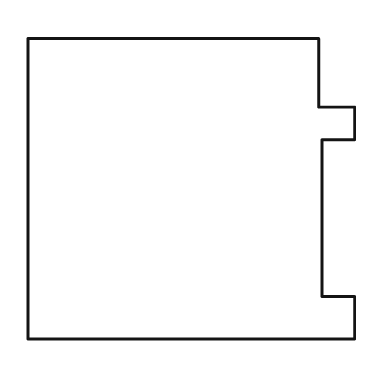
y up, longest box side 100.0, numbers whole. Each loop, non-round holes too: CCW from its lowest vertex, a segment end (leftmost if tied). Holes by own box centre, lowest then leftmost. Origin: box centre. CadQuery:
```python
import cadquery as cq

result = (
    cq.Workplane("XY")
    .moveTo(-50.0, -46.0)
    .lineTo(50.0, -46.0)
    .lineTo(50.0, -33.0)
    .lineTo(40.0, -33.0)
    .lineTo(40.0, 15.0)
    .lineTo(50.0, 15.0)
    .lineTo(50.0, 25.0)
    .lineTo(39.0, 25.0)
    .lineTo(39.0, 46.0)
    .lineTo(-50.0, 46.0)
    .close()
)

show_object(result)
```